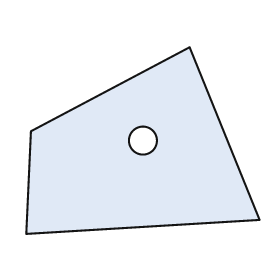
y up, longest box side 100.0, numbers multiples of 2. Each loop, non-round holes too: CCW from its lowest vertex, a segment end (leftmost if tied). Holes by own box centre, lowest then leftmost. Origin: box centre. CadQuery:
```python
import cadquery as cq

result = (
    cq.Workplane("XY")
    .moveTo(-50.0, -40.0)
    .lineTo(50.0, -34.0)
    .lineTo(20.0, 40.0)
    .lineTo(-48.0, 4.0)
    .close()
    .moveTo(0.0, 0.0)
    .circle(6.0)
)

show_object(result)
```